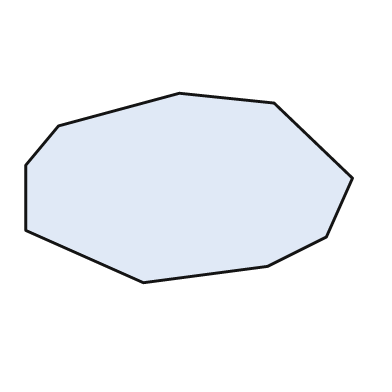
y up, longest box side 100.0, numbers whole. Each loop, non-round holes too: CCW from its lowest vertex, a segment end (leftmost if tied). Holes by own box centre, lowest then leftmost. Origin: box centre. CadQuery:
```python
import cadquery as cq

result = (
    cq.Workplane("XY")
    .moveTo(-14.0, -29.0)
    .lineTo(24.0, -24.0)
    .lineTo(42.0, -15.0)
    .lineTo(50.0, 3.0)
    .lineTo(26.0, 26.0)
    .lineTo(-3.0, 29.0)
    .lineTo(-40.0, 19.0)
    .lineTo(-50.0, 7.0)
    .lineTo(-50.0, -13.0)
    .close()
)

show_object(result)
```